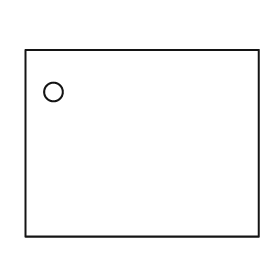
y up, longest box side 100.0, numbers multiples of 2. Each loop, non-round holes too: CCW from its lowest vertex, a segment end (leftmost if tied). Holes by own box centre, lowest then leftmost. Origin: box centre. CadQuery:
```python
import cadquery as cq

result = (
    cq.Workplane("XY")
    .moveTo(-50.0, -40.0)
    .lineTo(50.0, -40.0)
    .lineTo(50.0, 40.0)
    .lineTo(-50.0, 40.0)
    .close()
    .moveTo(-38.0, 22.0)
    .circle(4.0)
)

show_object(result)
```